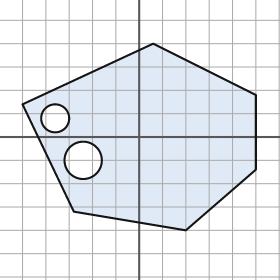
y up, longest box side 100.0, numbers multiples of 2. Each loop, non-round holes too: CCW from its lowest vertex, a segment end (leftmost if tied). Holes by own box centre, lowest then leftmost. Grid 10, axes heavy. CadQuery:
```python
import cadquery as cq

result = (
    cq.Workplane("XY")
    .moveTo(20.0, -40.0)
    .lineTo(50.0, -14.0)
    .lineTo(50.0, 18.0)
    .lineTo(6.0, 40.0)
    .lineTo(-50.0, 14.0)
    .lineTo(-28.0, -32.0)
    .close()
    .moveTo(-24.0, -10.0)
    .circle(8.0)
    .moveTo(-36.0, 8.0)
    .circle(6.0)
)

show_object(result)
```